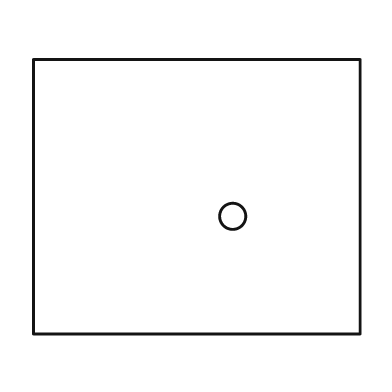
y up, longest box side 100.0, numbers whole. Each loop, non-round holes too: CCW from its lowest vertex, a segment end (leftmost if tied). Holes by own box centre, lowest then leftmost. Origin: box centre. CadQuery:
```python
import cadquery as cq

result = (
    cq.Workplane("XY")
    .moveTo(-50.0, -42.0)
    .lineTo(50.0, -42.0)
    .lineTo(50.0, 42.0)
    .lineTo(-50.0, 42.0)
    .close()
    .moveTo(11.0, -6.0)
    .circle(4.0)
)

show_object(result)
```